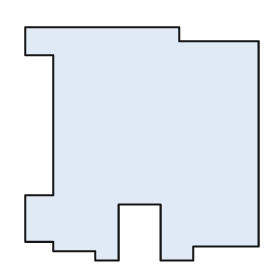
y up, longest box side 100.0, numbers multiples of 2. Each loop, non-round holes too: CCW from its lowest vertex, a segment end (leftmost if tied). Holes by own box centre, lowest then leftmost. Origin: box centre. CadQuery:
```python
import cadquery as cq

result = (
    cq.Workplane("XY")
    .moveTo(-20.0, -50.0)
    .lineTo(-10.0, -50.0)
    .lineTo(-10.0, -26.0)
    .lineTo(8.0, -26.0)
    .lineTo(8.0, -50.0)
    .lineTo(22.0, -50.0)
    .lineTo(22.0, -44.0)
    .lineTo(50.0, -44.0)
    .lineTo(50.0, 44.0)
    .lineTo(16.0, 44.0)
    .lineTo(16.0, 50.0)
    .lineTo(-50.0, 50.0)
    .lineTo(-50.0, 38.0)
    .lineTo(-38.0, 38.0)
    .lineTo(-38.0, -22.0)
    .lineTo(-50.0, -22.0)
    .lineTo(-50.0, -42.0)
    .lineTo(-38.0, -42.0)
    .lineTo(-38.0, -46.0)
    .lineTo(-20.0, -46.0)
    .close()
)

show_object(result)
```